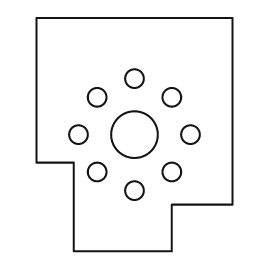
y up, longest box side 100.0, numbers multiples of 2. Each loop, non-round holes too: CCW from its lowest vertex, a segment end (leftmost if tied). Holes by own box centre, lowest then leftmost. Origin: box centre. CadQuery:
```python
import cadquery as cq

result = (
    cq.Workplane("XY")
    .moveTo(-26.0, -50.0)
    .lineTo(16.0, -50.0)
    .lineTo(16.0, -30.0)
    .lineTo(42.0, -30.0)
    .lineTo(42.0, 50.0)
    .lineTo(-42.0, 50.0)
    .lineTo(-42.0, -12.0)
    .lineTo(-26.0, -12.0)
    .close()
    .moveTo(0.0, -24.0)
    .circle(4.0)
    .moveTo(-16.0, -16.0)
    .circle(4.0)
    .moveTo(16.0, -16.0)
    .circle(4.0)
    .moveTo(-24.0, 0.0)
    .circle(4.0)
    .moveTo(0.0, 0.0)
    .circle(10.0)
    .moveTo(24.0, 0.0)
    .circle(4.0)
    .moveTo(-16.0, 16.0)
    .circle(4.0)
    .moveTo(16.0, 16.0)
    .circle(4.0)
    .moveTo(0.0, 24.0)
    .circle(4.0)
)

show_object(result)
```